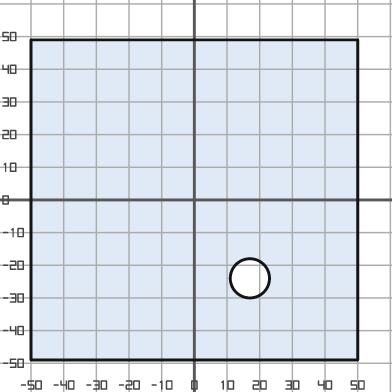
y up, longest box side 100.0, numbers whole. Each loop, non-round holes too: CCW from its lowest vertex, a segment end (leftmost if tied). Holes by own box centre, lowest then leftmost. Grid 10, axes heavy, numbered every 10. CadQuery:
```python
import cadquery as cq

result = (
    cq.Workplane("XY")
    .moveTo(-50.0, -49.0)
    .lineTo(50.0, -49.0)
    .lineTo(50.0, 49.0)
    .lineTo(-50.0, 49.0)
    .close()
    .moveTo(17.0, -24.0)
    .circle(6.0)
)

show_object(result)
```